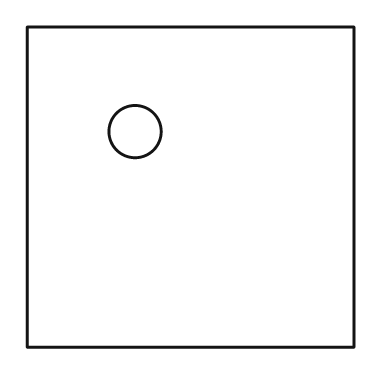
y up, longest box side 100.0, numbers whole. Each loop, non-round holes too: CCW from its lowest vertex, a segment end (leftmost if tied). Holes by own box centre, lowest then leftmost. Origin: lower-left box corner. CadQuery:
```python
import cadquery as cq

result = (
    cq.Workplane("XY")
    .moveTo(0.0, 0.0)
    .lineTo(100.0, 0.0)
    .lineTo(100.0, 98.0)
    .lineTo(0.0, 98.0)
    .close()
    .moveTo(33.0, 66.0)
    .circle(8.0)
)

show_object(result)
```